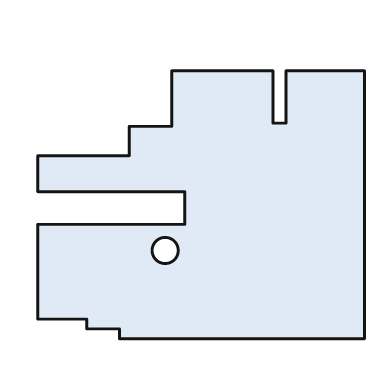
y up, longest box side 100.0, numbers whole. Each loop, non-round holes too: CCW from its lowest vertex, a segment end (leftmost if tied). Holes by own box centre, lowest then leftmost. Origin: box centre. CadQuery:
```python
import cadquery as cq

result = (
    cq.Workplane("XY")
    .moveTo(-25.0, -41.0)
    .lineTo(50.0, -41.0)
    .lineTo(50.0, 41.0)
    .lineTo(26.0, 41.0)
    .lineTo(26.0, 25.0)
    .lineTo(22.0, 25.0)
    .lineTo(22.0, 41.0)
    .lineTo(-9.0, 41.0)
    .lineTo(-9.0, 24.0)
    .lineTo(-22.0, 24.0)
    .lineTo(-22.0, 15.0)
    .lineTo(-50.0, 15.0)
    .lineTo(-50.0, 4.0)
    .lineTo(-5.0, 4.0)
    .lineTo(-5.0, -6.0)
    .lineTo(-50.0, -6.0)
    .lineTo(-50.0, -35.0)
    .lineTo(-35.0, -35.0)
    .lineTo(-35.0, -38.0)
    .lineTo(-25.0, -38.0)
    .close()
    .moveTo(-11.0, -14.0)
    .circle(4.0)
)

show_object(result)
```